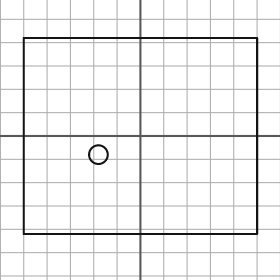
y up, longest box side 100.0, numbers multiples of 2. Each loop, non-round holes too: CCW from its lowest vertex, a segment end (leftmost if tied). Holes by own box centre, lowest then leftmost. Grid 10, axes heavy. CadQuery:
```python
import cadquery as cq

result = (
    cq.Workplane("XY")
    .moveTo(-50.0, -42.0)
    .lineTo(50.0, -42.0)
    .lineTo(50.0, 42.0)
    .lineTo(-50.0, 42.0)
    .close()
    .moveTo(-18.0, -8.0)
    .circle(4.0)
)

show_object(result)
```